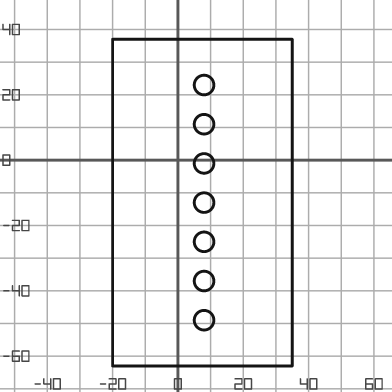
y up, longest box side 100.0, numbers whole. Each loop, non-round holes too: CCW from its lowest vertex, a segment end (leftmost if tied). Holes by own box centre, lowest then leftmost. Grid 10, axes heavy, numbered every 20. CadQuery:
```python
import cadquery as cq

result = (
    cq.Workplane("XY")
    .moveTo(-20.0, -63.0)
    .lineTo(35.0, -63.0)
    .lineTo(35.0, 37.0)
    .lineTo(-20.0, 37.0)
    .close()
    .moveTo(8.0, -49.0)
    .circle(3.0)
    .moveTo(8.0, -37.0)
    .circle(3.0)
    .moveTo(8.0, -25.0)
    .circle(3.0)
    .moveTo(8.0, -13.0)
    .circle(3.0)
    .moveTo(8.0, -1.0)
    .circle(3.0)
    .moveTo(8.0, 11.0)
    .circle(3.0)
    .moveTo(8.0, 23.0)
    .circle(3.0)
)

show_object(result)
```